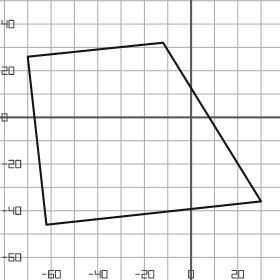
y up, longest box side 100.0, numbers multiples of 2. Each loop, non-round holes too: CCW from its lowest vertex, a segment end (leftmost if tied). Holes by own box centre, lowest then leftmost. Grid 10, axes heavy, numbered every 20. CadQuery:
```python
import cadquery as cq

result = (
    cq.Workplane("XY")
    .moveTo(-62.0, -46.0)
    .lineTo(30.0, -36.0)
    .lineTo(-12.0, 32.0)
    .lineTo(-70.0, 26.0)
    .close()
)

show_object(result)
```